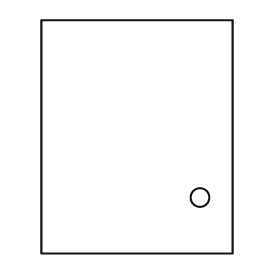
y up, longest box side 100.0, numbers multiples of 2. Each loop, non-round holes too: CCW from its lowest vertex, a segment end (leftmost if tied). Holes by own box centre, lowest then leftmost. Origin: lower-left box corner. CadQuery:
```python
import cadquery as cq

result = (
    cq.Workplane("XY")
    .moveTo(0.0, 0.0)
    .lineTo(82.0, 0.0)
    .lineTo(82.0, 100.0)
    .lineTo(0.0, 100.0)
    .close()
    .moveTo(68.0, 24.0)
    .circle(4.0)
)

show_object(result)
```